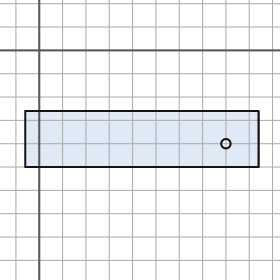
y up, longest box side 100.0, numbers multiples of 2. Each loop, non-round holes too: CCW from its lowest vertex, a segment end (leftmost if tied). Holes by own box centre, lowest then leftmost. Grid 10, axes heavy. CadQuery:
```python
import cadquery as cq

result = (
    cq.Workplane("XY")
    .moveTo(-6.0, -50.0)
    .lineTo(94.0, -50.0)
    .lineTo(94.0, -26.0)
    .lineTo(-6.0, -26.0)
    .close()
    .moveTo(80.0, -40.0)
    .circle(2.0)
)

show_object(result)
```